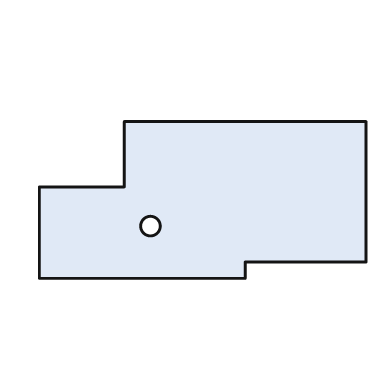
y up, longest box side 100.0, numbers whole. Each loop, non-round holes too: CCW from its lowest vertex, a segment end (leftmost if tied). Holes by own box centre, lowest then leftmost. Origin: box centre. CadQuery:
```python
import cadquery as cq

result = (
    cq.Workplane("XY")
    .moveTo(-50.0, -24.0)
    .lineTo(13.0, -24.0)
    .lineTo(13.0, -19.0)
    .lineTo(50.0, -19.0)
    .lineTo(50.0, 24.0)
    .lineTo(-24.0, 24.0)
    .lineTo(-24.0, 4.0)
    .lineTo(-50.0, 4.0)
    .close()
    .moveTo(-16.0, -8.0)
    .circle(3.0)
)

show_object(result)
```